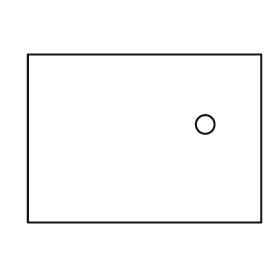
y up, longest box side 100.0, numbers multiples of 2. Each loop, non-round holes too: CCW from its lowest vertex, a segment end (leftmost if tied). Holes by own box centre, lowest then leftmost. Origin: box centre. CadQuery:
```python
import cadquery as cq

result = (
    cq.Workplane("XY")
    .moveTo(-50.0, -36.0)
    .lineTo(50.0, -36.0)
    .lineTo(50.0, 36.0)
    .lineTo(-50.0, 36.0)
    .close()
    .moveTo(26.0, 6.0)
    .circle(4.0)
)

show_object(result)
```